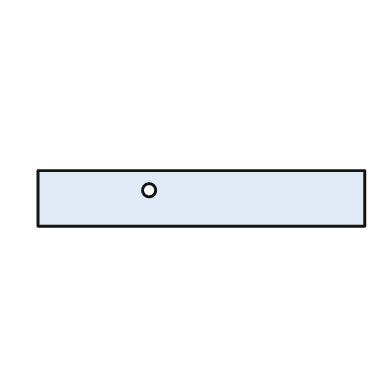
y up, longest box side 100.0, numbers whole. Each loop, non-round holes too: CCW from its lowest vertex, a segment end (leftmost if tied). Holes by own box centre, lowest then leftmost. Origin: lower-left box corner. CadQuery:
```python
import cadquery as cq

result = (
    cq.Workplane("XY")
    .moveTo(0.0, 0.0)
    .lineTo(100.0, 0.0)
    .lineTo(100.0, 17.0)
    .lineTo(0.0, 17.0)
    .close()
    .moveTo(34.0, 11.0)
    .circle(2.0)
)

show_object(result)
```